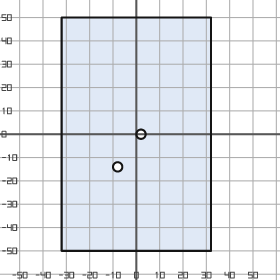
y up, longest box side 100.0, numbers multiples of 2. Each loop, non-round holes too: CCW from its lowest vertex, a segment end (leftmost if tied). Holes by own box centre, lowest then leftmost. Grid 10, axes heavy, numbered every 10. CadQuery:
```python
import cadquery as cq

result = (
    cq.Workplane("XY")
    .moveTo(-32.0, -50.0)
    .lineTo(32.0, -50.0)
    .lineTo(32.0, 50.0)
    .lineTo(-32.0, 50.0)
    .close()
    .moveTo(-8.0, -14.0)
    .circle(2.0)
    .moveTo(2.0, 0.0)
    .circle(2.0)
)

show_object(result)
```